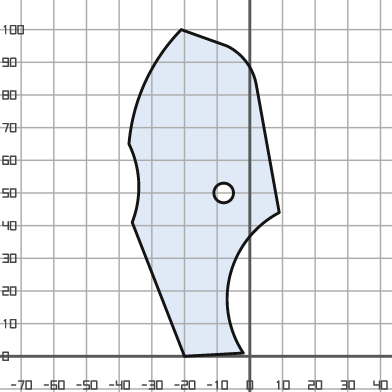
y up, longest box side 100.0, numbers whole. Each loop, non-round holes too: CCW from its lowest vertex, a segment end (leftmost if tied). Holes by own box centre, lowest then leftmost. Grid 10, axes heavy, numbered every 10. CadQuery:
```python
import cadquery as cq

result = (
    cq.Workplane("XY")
    .moveTo(-20.0, 0.0)
    .lineTo(-2.0, 1.0)
    .threePointArc((-6.0, 25.0), (9.0, 44.0))
    .lineTo(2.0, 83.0)
    .threePointArc((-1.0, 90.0), (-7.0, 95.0))
    .lineTo(-21.0, 100.0)
    .threePointArc((-32.0, 84.0), (-37.0, 65.0))
    .threePointArc((-34.0, 53.0), (-36.0, 41.0))
    .close()
    .moveTo(-8.0, 50.0)
    .circle(3.0)
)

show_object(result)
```